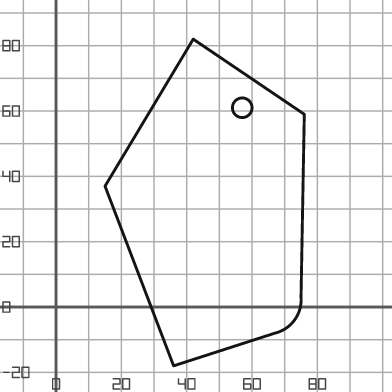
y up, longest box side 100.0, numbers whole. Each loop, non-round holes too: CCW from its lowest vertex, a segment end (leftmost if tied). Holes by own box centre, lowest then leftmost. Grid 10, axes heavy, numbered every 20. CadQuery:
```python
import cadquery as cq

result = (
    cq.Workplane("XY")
    .moveTo(36.0, -18.0)
    .lineTo(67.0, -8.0)
    .threePointArc((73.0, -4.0), (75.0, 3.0))
    .lineTo(76.0, 59.0)
    .lineTo(42.0, 82.0)
    .lineTo(15.0, 37.0)
    .close()
    .moveTo(57.0, 61.0)
    .circle(3.0)
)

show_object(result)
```